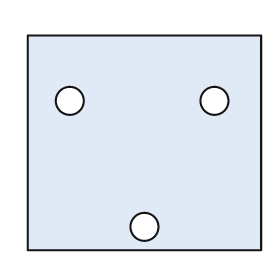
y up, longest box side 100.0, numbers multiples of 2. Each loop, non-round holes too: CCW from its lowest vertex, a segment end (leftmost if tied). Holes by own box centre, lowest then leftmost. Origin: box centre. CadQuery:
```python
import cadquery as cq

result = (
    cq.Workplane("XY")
    .moveTo(-50.0, -46.0)
    .lineTo(50.0, -46.0)
    .lineTo(50.0, 46.0)
    .lineTo(-50.0, 46.0)
    .close()
    .moveTo(0.0, -36.0)
    .circle(6.0)
    .moveTo(-32.0, 18.0)
    .circle(6.0)
    .moveTo(30.0, 18.0)
    .circle(6.0)
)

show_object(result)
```